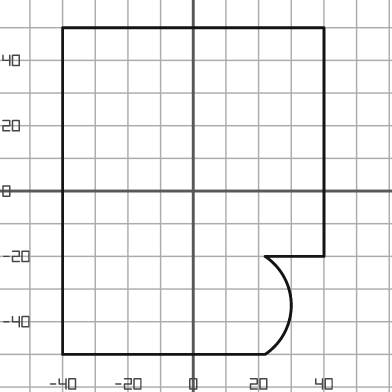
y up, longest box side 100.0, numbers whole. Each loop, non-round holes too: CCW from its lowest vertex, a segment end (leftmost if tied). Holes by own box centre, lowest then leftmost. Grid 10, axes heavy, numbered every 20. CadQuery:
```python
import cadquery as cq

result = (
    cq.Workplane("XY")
    .moveTo(-40.0, -50.0)
    .lineTo(22.0, -50.0)
    .threePointArc((30.0, -35.0), (22.0, -20.0))
    .lineTo(40.0, -20.0)
    .lineTo(40.0, 50.0)
    .lineTo(-40.0, 50.0)
    .close()
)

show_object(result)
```